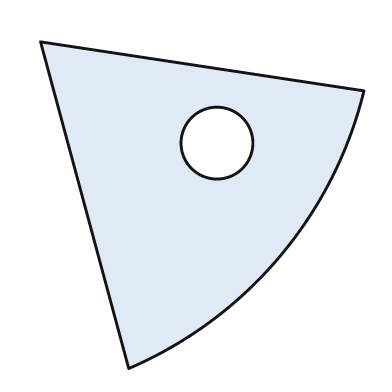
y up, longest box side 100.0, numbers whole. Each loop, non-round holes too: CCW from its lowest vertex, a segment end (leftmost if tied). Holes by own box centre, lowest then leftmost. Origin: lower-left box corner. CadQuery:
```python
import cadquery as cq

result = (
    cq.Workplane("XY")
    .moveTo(27.0, 0.0)
    .threePointArc((73.0, 34.0), (99.0, 85.0))
    .lineTo(0.0, 100.0)
    .close()
    .moveTo(54.0, 69.0)
    .circle(11.0)
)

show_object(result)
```